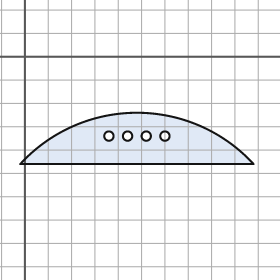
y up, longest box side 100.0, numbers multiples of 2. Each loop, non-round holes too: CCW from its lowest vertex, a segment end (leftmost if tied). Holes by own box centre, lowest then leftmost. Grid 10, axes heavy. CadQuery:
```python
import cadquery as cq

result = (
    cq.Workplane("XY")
    .moveTo(-2.0, -46.0)
    .lineTo(98.0, -46.0)
    .threePointArc((48.0, -24.0), (-2.0, -46.0))
    .close()
    .moveTo(36.0, -34.0)
    .circle(2.0)
    .moveTo(44.0, -34.0)
    .circle(2.0)
    .moveTo(52.0, -34.0)
    .circle(2.0)
    .moveTo(60.0, -34.0)
    .circle(2.0)
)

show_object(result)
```